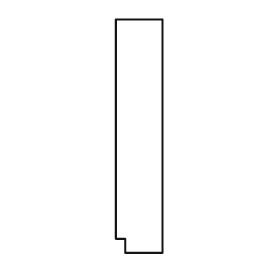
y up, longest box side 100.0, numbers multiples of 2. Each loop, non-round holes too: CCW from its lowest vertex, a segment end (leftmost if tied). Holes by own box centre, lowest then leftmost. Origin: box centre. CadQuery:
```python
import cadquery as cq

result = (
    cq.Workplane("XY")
    .moveTo(-6.0, -50.0)
    .lineTo(10.0, -50.0)
    .lineTo(10.0, 50.0)
    .lineTo(-10.0, 50.0)
    .lineTo(-10.0, -44.0)
    .lineTo(-6.0, -44.0)
    .close()
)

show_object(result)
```